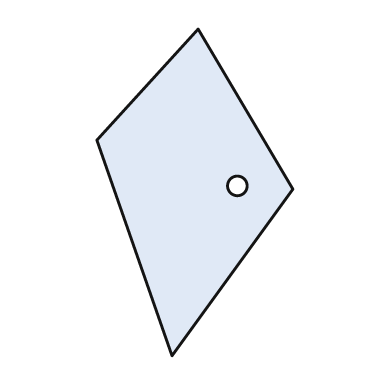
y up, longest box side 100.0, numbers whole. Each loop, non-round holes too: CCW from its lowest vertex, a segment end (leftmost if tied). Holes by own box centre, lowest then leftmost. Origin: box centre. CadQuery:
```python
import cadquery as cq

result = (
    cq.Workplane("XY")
    .moveTo(-7.0, -50.0)
    .lineTo(30.0, 1.0)
    .lineTo(1.0, 50.0)
    .lineTo(-30.0, 16.0)
    .close()
    .moveTo(13.0, 2.0)
    .circle(3.0)
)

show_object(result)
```